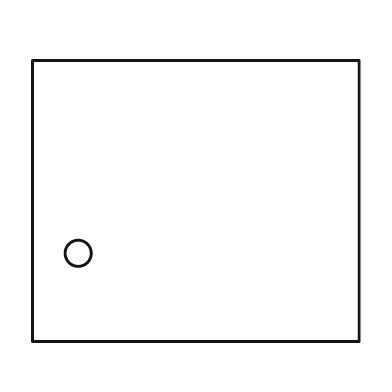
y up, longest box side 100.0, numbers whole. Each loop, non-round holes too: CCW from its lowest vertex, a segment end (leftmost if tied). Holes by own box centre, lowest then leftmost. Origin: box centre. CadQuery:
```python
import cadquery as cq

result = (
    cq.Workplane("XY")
    .moveTo(-50.0, -43.0)
    .lineTo(50.0, -43.0)
    .lineTo(50.0, 43.0)
    .lineTo(-50.0, 43.0)
    .close()
    .moveTo(-36.0, -16.0)
    .circle(4.0)
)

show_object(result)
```